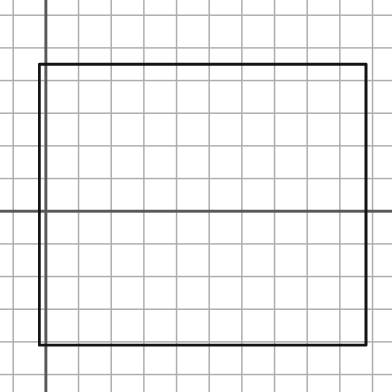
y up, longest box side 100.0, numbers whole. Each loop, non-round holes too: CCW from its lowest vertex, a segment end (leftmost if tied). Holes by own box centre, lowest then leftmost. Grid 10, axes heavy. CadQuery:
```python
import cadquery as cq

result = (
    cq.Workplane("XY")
    .moveTo(-2.0, -41.0)
    .lineTo(98.0, -41.0)
    .lineTo(98.0, 45.0)
    .lineTo(-2.0, 45.0)
    .close()
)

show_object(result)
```